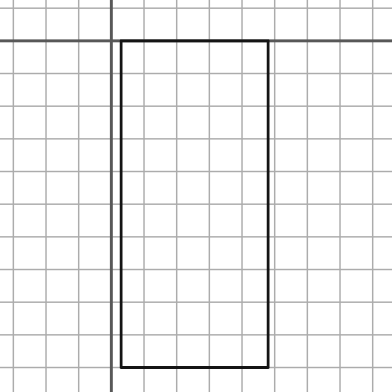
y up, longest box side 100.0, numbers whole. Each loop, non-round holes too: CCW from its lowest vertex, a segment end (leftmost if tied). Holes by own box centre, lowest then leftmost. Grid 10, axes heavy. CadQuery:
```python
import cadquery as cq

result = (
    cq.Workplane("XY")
    .moveTo(3.0, -100.0)
    .lineTo(48.0, -100.0)
    .lineTo(48.0, 0.0)
    .lineTo(3.0, 0.0)
    .close()
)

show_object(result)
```